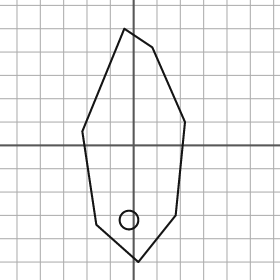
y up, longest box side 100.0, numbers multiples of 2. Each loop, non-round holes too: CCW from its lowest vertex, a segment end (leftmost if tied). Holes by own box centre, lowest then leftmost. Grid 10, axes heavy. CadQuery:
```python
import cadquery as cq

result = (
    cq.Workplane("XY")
    .moveTo(2.0, -50.0)
    .lineTo(18.0, -30.0)
    .lineTo(22.0, 10.0)
    .lineTo(8.0, 42.0)
    .lineTo(-4.0, 50.0)
    .lineTo(-22.0, 6.0)
    .lineTo(-16.0, -34.0)
    .close()
    .moveTo(-2.0, -32.0)
    .circle(4.0)
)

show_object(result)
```